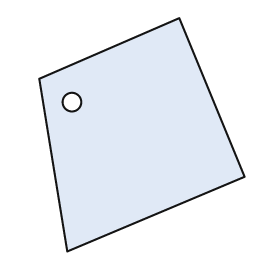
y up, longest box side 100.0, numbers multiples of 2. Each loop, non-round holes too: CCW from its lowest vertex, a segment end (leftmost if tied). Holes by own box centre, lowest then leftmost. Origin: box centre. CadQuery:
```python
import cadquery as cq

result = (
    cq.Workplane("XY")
    .moveTo(-32.0, -50.0)
    .lineTo(44.0, -18.0)
    .lineTo(16.0, 50.0)
    .lineTo(-44.0, 24.0)
    .close()
    .moveTo(-30.0, 14.0)
    .circle(4.0)
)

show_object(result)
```